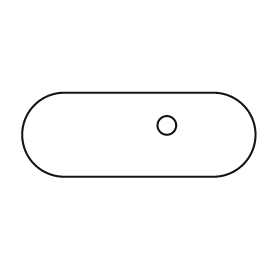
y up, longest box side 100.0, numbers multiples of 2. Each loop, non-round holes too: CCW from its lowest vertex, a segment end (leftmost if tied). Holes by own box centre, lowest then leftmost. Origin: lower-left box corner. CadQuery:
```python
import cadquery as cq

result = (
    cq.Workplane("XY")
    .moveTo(18.0, 0.0)
    .lineTo(82.0, 0.0)
    .threePointArc((100.0, 18.0), (82.0, 36.0))
    .lineTo(18.0, 36.0)
    .threePointArc((0.0, 18.0), (18.0, 0.0))
    .close()
    .moveTo(62.0, 22.0)
    .circle(4.0)
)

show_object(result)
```